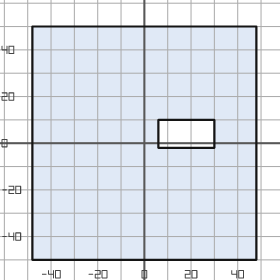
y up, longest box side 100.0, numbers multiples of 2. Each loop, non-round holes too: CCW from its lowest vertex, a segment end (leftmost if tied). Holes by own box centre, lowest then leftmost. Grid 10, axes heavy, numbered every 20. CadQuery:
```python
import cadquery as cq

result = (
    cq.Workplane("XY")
    .moveTo(-48.0, -50.0)
    .lineTo(48.0, -50.0)
    .lineTo(48.0, 50.0)
    .lineTo(-48.0, 50.0)
    .close()
    .moveTo(6.0, -2.0)
    .lineTo(30.0, -2.0)
    .lineTo(30.0, 10.0)
    .lineTo(6.0, 10.0)
    .close()
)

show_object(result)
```